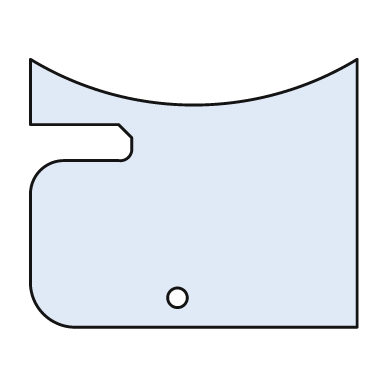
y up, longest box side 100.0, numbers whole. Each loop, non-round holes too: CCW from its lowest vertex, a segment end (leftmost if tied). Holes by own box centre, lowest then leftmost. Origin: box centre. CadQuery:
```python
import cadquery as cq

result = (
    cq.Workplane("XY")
    .moveTo(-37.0, -41.0)
    .lineTo(50.0, -41.0)
    .lineTo(50.0, 41.0)
    .threePointArc((0.0, 27.0), (-50.0, 41.0))
    .lineTo(-50.0, 21.0)
    .lineTo(-23.0, 21.0)
    .lineTo(-19.0, 17.0)
    .lineTo(-19.0, 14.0)
    .threePointArc((-20.0, 11.0), (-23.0, 10.0))
    .lineTo(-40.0, 10.0)
    .threePointArc((-47.0, 7.0), (-50.0, 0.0))
    .lineTo(-50.0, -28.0)
    .threePointArc((-46.0, -37.0), (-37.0, -41.0))
    .close()
    .moveTo(-5.0, -32.0)
    .circle(3.0)
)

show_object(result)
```